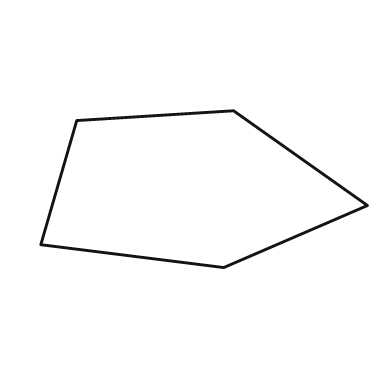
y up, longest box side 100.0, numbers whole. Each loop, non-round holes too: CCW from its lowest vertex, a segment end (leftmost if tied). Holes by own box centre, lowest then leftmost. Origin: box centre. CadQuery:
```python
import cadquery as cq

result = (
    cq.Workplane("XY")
    .moveTo(6.0, -24.0)
    .lineTo(50.0, -5.0)
    .lineTo(9.0, 24.0)
    .lineTo(-39.0, 21.0)
    .lineTo(-50.0, -17.0)
    .close()
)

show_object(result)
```